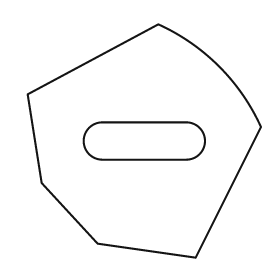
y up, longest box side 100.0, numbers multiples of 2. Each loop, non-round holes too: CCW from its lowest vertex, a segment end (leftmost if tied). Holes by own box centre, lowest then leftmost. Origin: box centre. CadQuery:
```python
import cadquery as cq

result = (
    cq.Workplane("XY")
    .moveTo(22.0, -50.0)
    .lineTo(50.0, 6.0)
    .threePointArc((32.0, 32.0), (6.0, 50.0))
    .lineTo(-50.0, 20.0)
    .lineTo(-44.0, -18.0)
    .lineTo(-20.0, -44.0)
    .close()
    .moveTo(-18.0, -8.0)
    .lineTo(18.0, -8.0)
    .threePointArc((26.0, 0.0), (18.0, 8.0))
    .lineTo(-18.0, 8.0)
    .threePointArc((-26.0, 0.0), (-18.0, -8.0))
    .close()
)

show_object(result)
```